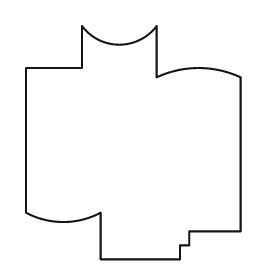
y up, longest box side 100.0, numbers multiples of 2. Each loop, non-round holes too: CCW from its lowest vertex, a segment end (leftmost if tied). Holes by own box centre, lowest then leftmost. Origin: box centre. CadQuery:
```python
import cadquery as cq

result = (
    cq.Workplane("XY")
    .moveTo(-14.0, -50.0)
    .lineTo(20.0, -50.0)
    .lineTo(20.0, -44.0)
    .lineTo(24.0, -44.0)
    .lineTo(24.0, -38.0)
    .lineTo(46.0, -38.0)
    .lineTo(46.0, 28.0)
    .threePointArc((28.0, 32.0), (10.0, 28.0))
    .lineTo(10.0, 50.0)
    .threePointArc((-6.0, 42.0), (-22.0, 50.0))
    .lineTo(-22.0, 32.0)
    .lineTo(-46.0, 32.0)
    .lineTo(-46.0, -30.0)
    .threePointArc((-30.0, -34.0), (-14.0, -30.0))
    .close()
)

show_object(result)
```